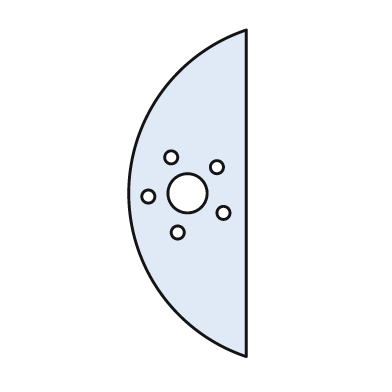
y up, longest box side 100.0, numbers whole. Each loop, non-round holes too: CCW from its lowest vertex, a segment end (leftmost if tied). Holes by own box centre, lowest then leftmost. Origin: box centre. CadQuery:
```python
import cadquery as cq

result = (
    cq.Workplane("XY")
    .moveTo(18.0, -50.0)
    .lineTo(18.0, 50.0)
    .threePointArc((-18.0, 0.0), (18.0, -50.0))
    .close()
    .moveTo(-3.0, -12.0)
    .circle(2.0)
    .moveTo(11.0, -6.0)
    .circle(2.0)
    .moveTo(-12.0, -1.0)
    .circle(2.0)
    .moveTo(0.0, 0.0)
    .circle(6.0)
    .moveTo(9.0, 8.0)
    .circle(2.0)
    .moveTo(-5.0, 11.0)
    .circle(2.0)
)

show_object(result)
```